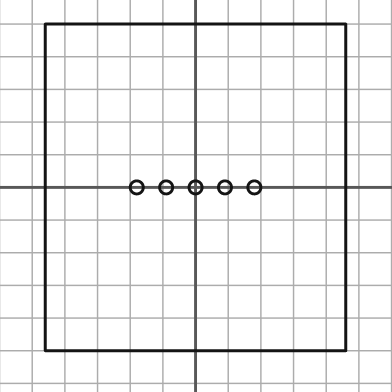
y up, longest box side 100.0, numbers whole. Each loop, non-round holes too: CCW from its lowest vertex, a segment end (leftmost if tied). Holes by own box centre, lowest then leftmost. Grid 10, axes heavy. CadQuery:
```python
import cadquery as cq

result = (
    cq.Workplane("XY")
    .moveTo(-46.0, -50.0)
    .lineTo(46.0, -50.0)
    .lineTo(46.0, 50.0)
    .lineTo(-46.0, 50.0)
    .close()
    .moveTo(-18.0, 0.0)
    .circle(2.0)
    .moveTo(-9.0, 0.0)
    .circle(2.0)
    .moveTo(0.0, 0.0)
    .circle(2.0)
    .moveTo(9.0, 0.0)
    .circle(2.0)
    .moveTo(18.0, 0.0)
    .circle(2.0)
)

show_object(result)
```